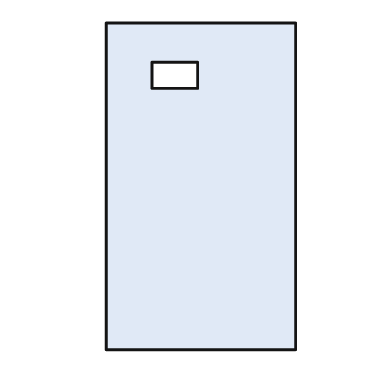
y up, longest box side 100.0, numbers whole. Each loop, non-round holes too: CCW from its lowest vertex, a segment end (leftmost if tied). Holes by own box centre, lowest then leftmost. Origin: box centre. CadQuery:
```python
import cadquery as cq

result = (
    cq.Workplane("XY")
    .moveTo(-29.0, -50.0)
    .lineTo(29.0, -50.0)
    .lineTo(29.0, 50.0)
    .lineTo(-29.0, 50.0)
    .close()
    .moveTo(-15.0, 30.0)
    .lineTo(-1.0, 30.0)
    .lineTo(-1.0, 38.0)
    .lineTo(-15.0, 38.0)
    .close()
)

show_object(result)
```